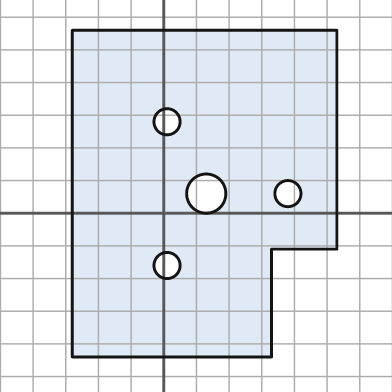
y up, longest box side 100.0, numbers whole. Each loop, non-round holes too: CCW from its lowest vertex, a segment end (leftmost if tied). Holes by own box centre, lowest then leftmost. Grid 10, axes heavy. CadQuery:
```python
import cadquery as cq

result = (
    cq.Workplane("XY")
    .moveTo(-28.0, -44.0)
    .lineTo(33.0, -44.0)
    .lineTo(33.0, -11.0)
    .lineTo(53.0, -11.0)
    .lineTo(53.0, 56.0)
    .lineTo(-28.0, 56.0)
    .close()
    .moveTo(1.0, -16.0)
    .circle(4.0)
    .moveTo(13.0, 6.0)
    .circle(6.0)
    .moveTo(38.0, 6.0)
    .circle(4.0)
    .moveTo(1.0, 28.0)
    .circle(4.0)
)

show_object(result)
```